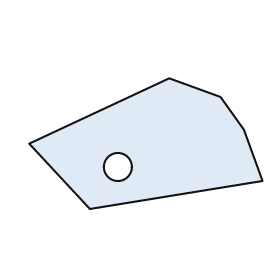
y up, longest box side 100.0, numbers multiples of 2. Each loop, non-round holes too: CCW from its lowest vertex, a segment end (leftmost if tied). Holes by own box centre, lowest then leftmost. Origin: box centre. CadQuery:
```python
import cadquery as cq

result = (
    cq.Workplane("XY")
    .moveTo(-24.0, -28.0)
    .lineTo(50.0, -16.0)
    .lineTo(42.0, 6.0)
    .lineTo(32.0, 20.0)
    .lineTo(10.0, 28.0)
    .lineTo(-50.0, 0.0)
    .close()
    .moveTo(-12.0, -10.0)
    .circle(6.0)
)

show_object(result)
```